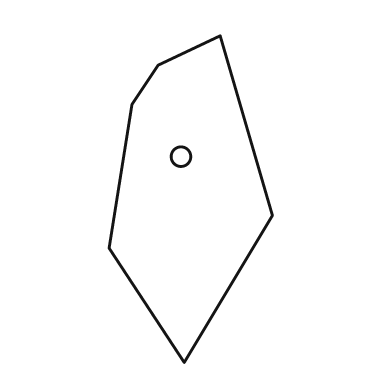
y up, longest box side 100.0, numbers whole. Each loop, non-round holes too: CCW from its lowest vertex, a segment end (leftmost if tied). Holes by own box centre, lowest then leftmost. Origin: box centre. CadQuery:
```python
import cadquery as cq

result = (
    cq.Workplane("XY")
    .moveTo(-2.0, -50.0)
    .lineTo(25.0, -5.0)
    .lineTo(9.0, 50.0)
    .lineTo(-10.0, 41.0)
    .lineTo(-18.0, 29.0)
    .lineTo(-25.0, -15.0)
    .close()
    .moveTo(-3.0, 13.0)
    .circle(3.0)
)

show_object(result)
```